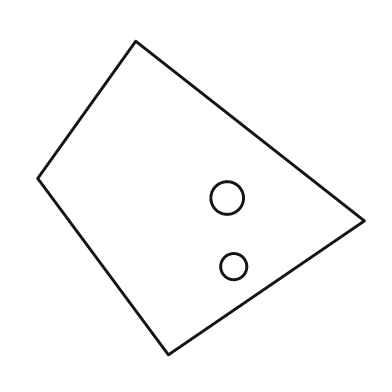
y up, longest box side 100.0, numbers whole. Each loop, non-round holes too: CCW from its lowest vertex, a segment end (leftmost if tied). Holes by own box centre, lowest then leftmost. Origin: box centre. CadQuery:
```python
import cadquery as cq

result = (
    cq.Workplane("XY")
    .moveTo(-10.0, -48.0)
    .lineTo(50.0, -7.0)
    .lineTo(-20.0, 48.0)
    .lineTo(-50.0, 6.0)
    .close()
    .moveTo(10.0, -21.0)
    .circle(4.0)
    .moveTo(8.0, 0.0)
    .circle(5.0)
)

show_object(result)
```